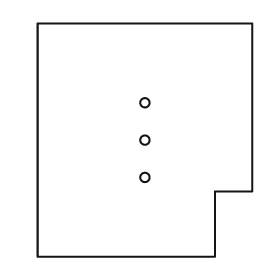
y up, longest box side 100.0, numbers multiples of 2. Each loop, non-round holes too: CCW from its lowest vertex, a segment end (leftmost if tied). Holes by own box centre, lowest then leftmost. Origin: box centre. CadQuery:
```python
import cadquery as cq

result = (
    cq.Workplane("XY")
    .moveTo(-46.0, -50.0)
    .lineTo(30.0, -50.0)
    .lineTo(30.0, -22.0)
    .lineTo(46.0, -22.0)
    .lineTo(46.0, 50.0)
    .lineTo(-46.0, 50.0)
    .close()
    .moveTo(0.0, -16.0)
    .circle(2.0)
    .moveTo(0.0, 0.0)
    .circle(2.0)
    .moveTo(0.0, 16.0)
    .circle(2.0)
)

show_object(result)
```